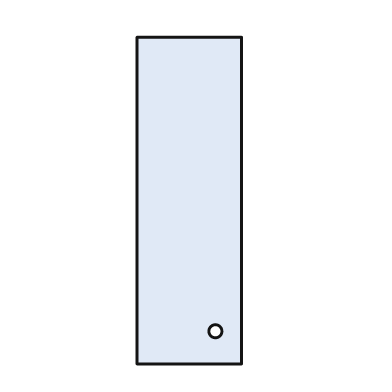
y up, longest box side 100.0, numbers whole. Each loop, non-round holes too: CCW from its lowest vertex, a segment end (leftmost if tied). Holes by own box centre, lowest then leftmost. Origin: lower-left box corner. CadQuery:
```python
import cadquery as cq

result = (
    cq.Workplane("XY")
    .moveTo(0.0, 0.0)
    .lineTo(32.0, 0.0)
    .lineTo(32.0, 100.0)
    .lineTo(0.0, 100.0)
    .close()
    .moveTo(24.0, 10.0)
    .circle(2.0)
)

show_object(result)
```